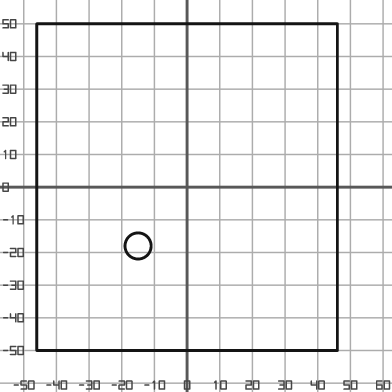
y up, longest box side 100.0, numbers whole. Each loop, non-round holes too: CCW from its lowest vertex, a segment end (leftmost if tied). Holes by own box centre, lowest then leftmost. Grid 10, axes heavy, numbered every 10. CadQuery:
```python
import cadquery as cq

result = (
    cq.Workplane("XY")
    .moveTo(-46.0, -50.0)
    .lineTo(46.0, -50.0)
    .lineTo(46.0, 50.0)
    .lineTo(-46.0, 50.0)
    .close()
    .moveTo(-15.0, -18.0)
    .circle(4.0)
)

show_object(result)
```